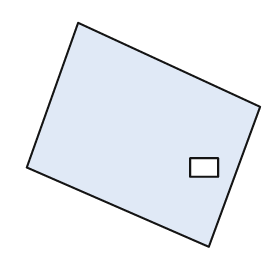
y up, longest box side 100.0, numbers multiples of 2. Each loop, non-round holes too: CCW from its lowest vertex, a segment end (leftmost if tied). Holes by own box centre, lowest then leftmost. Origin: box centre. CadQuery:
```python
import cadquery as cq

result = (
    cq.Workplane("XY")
    .moveTo(28.0, -48.0)
    .lineTo(50.0, 12.0)
    .lineTo(-28.0, 48.0)
    .lineTo(-50.0, -14.0)
    .close()
    .moveTo(20.0, -18.0)
    .lineTo(32.0, -18.0)
    .lineTo(32.0, -10.0)
    .lineTo(20.0, -10.0)
    .close()
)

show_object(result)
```